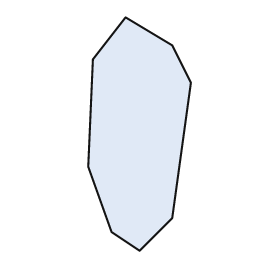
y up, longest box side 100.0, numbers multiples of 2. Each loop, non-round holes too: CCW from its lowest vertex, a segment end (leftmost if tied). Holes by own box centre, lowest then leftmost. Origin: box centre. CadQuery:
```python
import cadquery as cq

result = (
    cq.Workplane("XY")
    .moveTo(0.0, -50.0)
    .lineTo(14.0, -36.0)
    .lineTo(22.0, 22.0)
    .lineTo(14.0, 38.0)
    .lineTo(-6.0, 50.0)
    .lineTo(-20.0, 32.0)
    .lineTo(-22.0, -14.0)
    .lineTo(-12.0, -42.0)
    .close()
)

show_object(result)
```